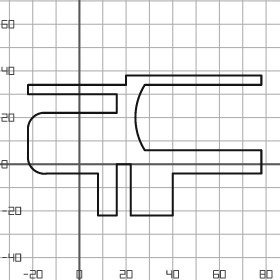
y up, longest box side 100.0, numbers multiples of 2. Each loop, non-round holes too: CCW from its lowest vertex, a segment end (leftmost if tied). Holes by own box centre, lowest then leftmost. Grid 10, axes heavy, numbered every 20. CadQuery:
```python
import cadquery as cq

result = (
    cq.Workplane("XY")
    .moveTo(8.0, -22.0)
    .lineTo(16.0, -22.0)
    .lineTo(16.0, 0.0)
    .lineTo(22.0, 0.0)
    .lineTo(22.0, -22.0)
    .lineTo(40.0, -22.0)
    .lineTo(40.0, -4.0)
    .lineTo(78.0, -4.0)
    .lineTo(78.0, 6.0)
    .lineTo(28.0, 6.0)
    .threePointArc((24.0, 20.0), (28.0, 34.0))
    .lineTo(78.0, 34.0)
    .lineTo(78.0, 38.0)
    .lineTo(20.0, 38.0)
    .lineTo(20.0, 34.0)
    .lineTo(-22.0, 34.0)
    .lineTo(-22.0, 30.0)
    .lineTo(16.0, 30.0)
    .lineTo(16.0, 22.0)
    .lineTo(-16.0, 22.0)
    .threePointArc((-20.0, 20.0), (-22.0, 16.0))
    .lineTo(-22.0, 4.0)
    .threePointArc((-20.0, -2.0), (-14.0, -4.0))
    .lineTo(8.0, -4.0)
    .close()
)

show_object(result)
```